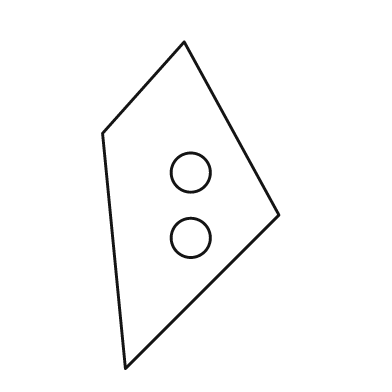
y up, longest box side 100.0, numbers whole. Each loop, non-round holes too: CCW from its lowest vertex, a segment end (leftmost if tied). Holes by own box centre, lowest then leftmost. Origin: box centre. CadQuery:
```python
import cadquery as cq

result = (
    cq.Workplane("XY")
    .moveTo(-20.0, -50.0)
    .lineTo(27.0, -3.0)
    .lineTo(-2.0, 50.0)
    .lineTo(-27.0, 22.0)
    .close()
    .moveTo(0.0, -10.0)
    .circle(6.0)
    .moveTo(0.0, 10.0)
    .circle(6.0)
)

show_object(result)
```